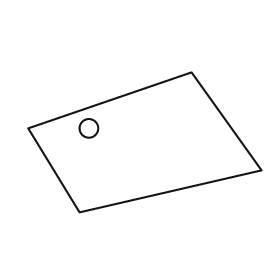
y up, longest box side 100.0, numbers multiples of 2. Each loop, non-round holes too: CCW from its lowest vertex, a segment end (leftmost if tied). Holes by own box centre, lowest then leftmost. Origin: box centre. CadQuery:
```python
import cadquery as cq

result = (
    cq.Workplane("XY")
    .moveTo(-28.0, -30.0)
    .lineTo(50.0, -12.0)
    .lineTo(20.0, 30.0)
    .lineTo(-50.0, 6.0)
    .close()
    .moveTo(-24.0, 6.0)
    .circle(4.0)
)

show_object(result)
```